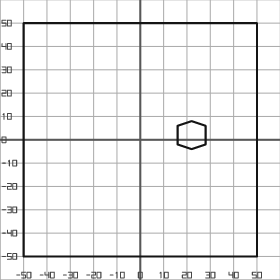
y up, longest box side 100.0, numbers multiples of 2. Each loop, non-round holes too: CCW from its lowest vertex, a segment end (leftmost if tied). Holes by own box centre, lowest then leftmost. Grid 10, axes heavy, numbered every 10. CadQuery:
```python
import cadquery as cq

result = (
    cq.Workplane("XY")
    .moveTo(-50.0, -50.0)
    .lineTo(50.0, -50.0)
    .lineTo(50.0, 50.0)
    .lineTo(-50.0, 50.0)
    .close()
    .moveTo(22.0, -4.0)
    .lineTo(28.0, -2.0)
    .lineTo(28.0, 6.0)
    .lineTo(22.0, 8.0)
    .lineTo(16.0, 6.0)
    .lineTo(16.0, -2.0)
    .close()
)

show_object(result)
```